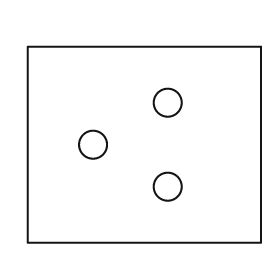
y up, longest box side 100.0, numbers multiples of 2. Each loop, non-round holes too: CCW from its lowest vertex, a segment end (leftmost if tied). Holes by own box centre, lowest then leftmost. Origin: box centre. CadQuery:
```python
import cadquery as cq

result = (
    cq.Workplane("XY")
    .moveTo(-50.0, -42.0)
    .lineTo(50.0, -42.0)
    .lineTo(50.0, 42.0)
    .lineTo(-50.0, 42.0)
    .close()
    .moveTo(10.0, -18.0)
    .circle(6.0)
    .moveTo(-22.0, 0.0)
    .circle(6.0)
    .moveTo(10.0, 18.0)
    .circle(6.0)
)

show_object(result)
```